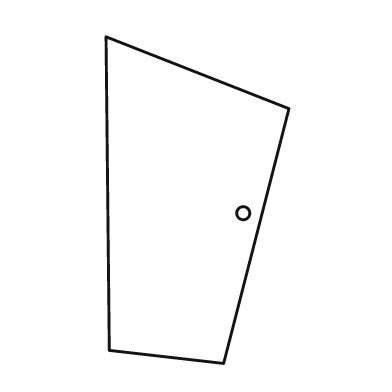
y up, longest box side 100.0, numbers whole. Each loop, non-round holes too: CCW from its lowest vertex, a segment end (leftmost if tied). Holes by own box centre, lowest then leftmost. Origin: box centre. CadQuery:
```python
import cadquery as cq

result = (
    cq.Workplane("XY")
    .moveTo(8.0, -50.0)
    .lineTo(28.0, 28.0)
    .lineTo(-28.0, 50.0)
    .lineTo(-27.0, -46.0)
    .close()
    .moveTo(14.0, -4.0)
    .circle(2.0)
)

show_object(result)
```